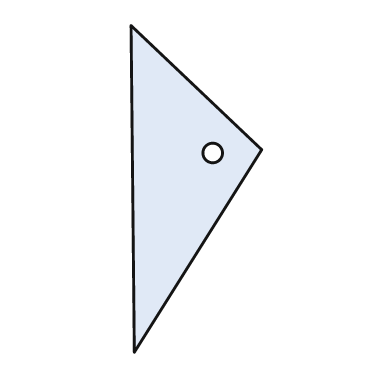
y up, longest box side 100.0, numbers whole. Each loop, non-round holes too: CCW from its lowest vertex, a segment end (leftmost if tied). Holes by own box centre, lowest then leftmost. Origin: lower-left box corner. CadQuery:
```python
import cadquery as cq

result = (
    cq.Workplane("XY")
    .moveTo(1.0, 0.0)
    .lineTo(40.0, 62.0)
    .lineTo(0.0, 100.0)
    .close()
    .moveTo(25.0, 61.0)
    .circle(3.0)
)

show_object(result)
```